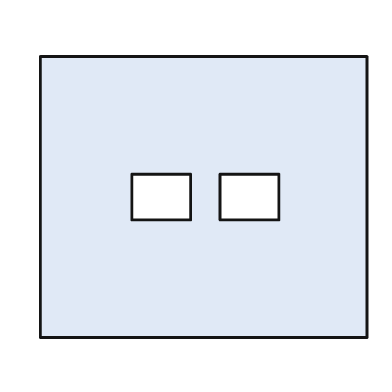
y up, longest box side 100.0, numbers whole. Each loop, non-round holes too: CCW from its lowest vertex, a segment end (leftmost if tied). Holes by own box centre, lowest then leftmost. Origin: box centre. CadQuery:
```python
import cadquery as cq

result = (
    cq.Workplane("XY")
    .moveTo(-50.0, -43.0)
    .lineTo(50.0, -43.0)
    .lineTo(50.0, 43.0)
    .lineTo(-50.0, 43.0)
    .close()
    .moveTo(-22.0, -7.0)
    .lineTo(-4.0, -7.0)
    .lineTo(-4.0, 7.0)
    .lineTo(-22.0, 7.0)
    .close()
    .moveTo(5.0, -7.0)
    .lineTo(23.0, -7.0)
    .lineTo(23.0, 7.0)
    .lineTo(5.0, 7.0)
    .close()
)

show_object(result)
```